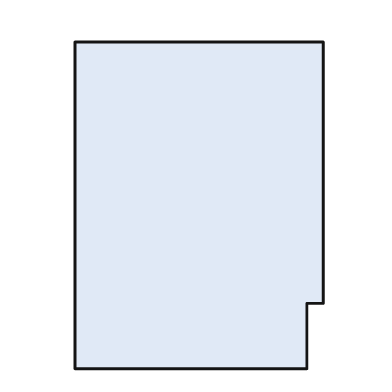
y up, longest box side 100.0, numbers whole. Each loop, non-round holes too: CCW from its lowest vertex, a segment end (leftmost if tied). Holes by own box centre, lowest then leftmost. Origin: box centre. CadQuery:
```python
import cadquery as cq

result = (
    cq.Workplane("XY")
    .moveTo(-38.0, -50.0)
    .lineTo(33.0, -50.0)
    .lineTo(33.0, -30.0)
    .lineTo(38.0, -30.0)
    .lineTo(38.0, 50.0)
    .lineTo(-38.0, 50.0)
    .close()
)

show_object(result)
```